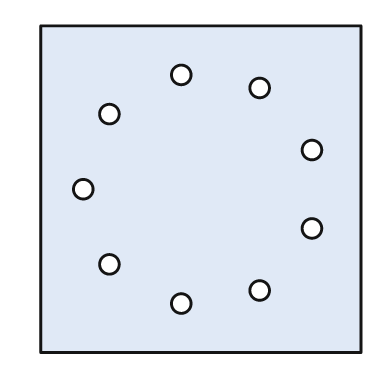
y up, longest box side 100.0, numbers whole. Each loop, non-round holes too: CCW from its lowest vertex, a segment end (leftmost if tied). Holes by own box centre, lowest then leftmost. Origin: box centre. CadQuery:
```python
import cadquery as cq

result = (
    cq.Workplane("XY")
    .moveTo(-49.0, -50.0)
    .lineTo(49.0, -50.0)
    .lineTo(49.0, 50.0)
    .lineTo(-49.0, 50.0)
    .close()
    .moveTo(-6.0, -35.0)
    .circle(3.0)
    .moveTo(18.0, -31.0)
    .circle(3.0)
    .moveTo(-28.0, -23.0)
    .circle(3.0)
    .moveTo(34.0, -12.0)
    .circle(3.0)
    .moveTo(-36.0, 0.0)
    .circle(3.0)
    .moveTo(34.0, 12.0)
    .circle(3.0)
    .moveTo(-28.0, 23.0)
    .circle(3.0)
    .moveTo(18.0, 31.0)
    .circle(3.0)
    .moveTo(-6.0, 35.0)
    .circle(3.0)
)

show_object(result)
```